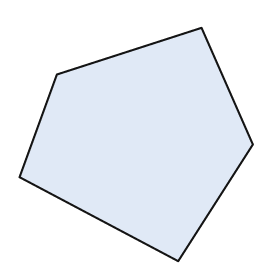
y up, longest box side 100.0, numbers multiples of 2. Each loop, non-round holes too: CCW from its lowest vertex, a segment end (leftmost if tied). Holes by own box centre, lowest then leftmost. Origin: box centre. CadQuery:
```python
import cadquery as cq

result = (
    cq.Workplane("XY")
    .moveTo(18.0, -50.0)
    .lineTo(50.0, 0.0)
    .lineTo(28.0, 50.0)
    .lineTo(-34.0, 30.0)
    .lineTo(-50.0, -14.0)
    .close()
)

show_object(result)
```